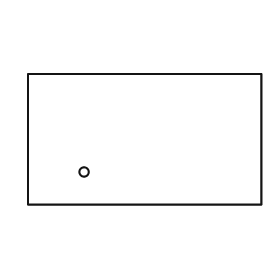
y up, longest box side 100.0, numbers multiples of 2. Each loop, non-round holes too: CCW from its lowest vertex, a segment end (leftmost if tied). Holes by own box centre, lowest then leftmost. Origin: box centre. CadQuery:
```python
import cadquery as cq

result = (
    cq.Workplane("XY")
    .moveTo(-50.0, -28.0)
    .lineTo(50.0, -28.0)
    .lineTo(50.0, 28.0)
    .lineTo(-50.0, 28.0)
    .close()
    .moveTo(-26.0, -14.0)
    .circle(2.0)
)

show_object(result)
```